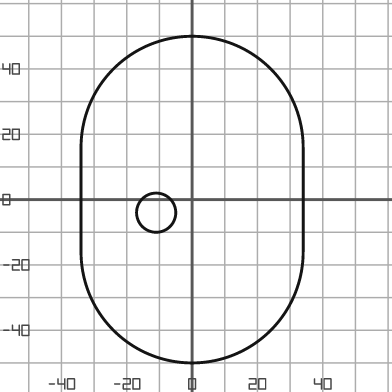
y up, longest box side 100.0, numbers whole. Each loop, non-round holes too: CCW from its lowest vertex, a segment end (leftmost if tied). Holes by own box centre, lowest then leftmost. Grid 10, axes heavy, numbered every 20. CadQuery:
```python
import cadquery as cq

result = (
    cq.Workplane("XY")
    .moveTo(-34.0, -16.0)
    .threePointArc((0.0, -50.0), (34.0, -16.0))
    .lineTo(34.0, 16.0)
    .threePointArc((0.0, 50.0), (-34.0, 16.0))
    .close()
    .moveTo(-11.0, -4.0)
    .circle(6.0)
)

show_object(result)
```